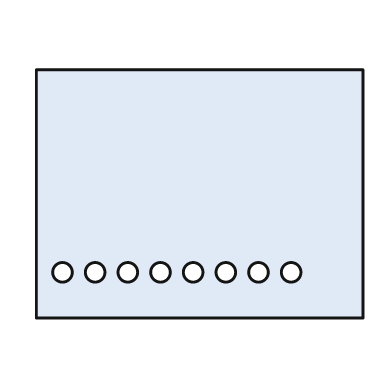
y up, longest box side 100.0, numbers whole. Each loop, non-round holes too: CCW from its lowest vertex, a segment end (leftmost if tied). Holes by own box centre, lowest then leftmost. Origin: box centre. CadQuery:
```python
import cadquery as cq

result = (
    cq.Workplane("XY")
    .moveTo(-50.0, -38.0)
    .lineTo(50.0, -38.0)
    .lineTo(50.0, 38.0)
    .lineTo(-50.0, 38.0)
    .close()
    .moveTo(-42.0, -24.0)
    .circle(3.0)
    .moveTo(-32.0, -24.0)
    .circle(3.0)
    .moveTo(-22.0, -24.0)
    .circle(3.0)
    .moveTo(-12.0, -24.0)
    .circle(3.0)
    .moveTo(-2.0, -24.0)
    .circle(3.0)
    .moveTo(8.0, -24.0)
    .circle(3.0)
    .moveTo(18.0, -24.0)
    .circle(3.0)
    .moveTo(28.0, -24.0)
    .circle(3.0)
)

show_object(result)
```